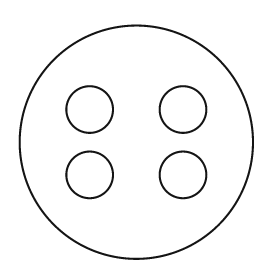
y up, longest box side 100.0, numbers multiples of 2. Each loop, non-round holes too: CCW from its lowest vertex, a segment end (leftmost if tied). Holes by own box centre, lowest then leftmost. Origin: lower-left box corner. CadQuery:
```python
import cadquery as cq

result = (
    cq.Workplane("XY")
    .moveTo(50.0, 50.0)
    .circle(50.0)
    .moveTo(30.0, 36.0)
    .circle(10.0)
    .moveTo(70.0, 36.0)
    .circle(10.0)
    .moveTo(30.0, 64.0)
    .circle(10.0)
    .moveTo(70.0, 64.0)
    .circle(10.0)
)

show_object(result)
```